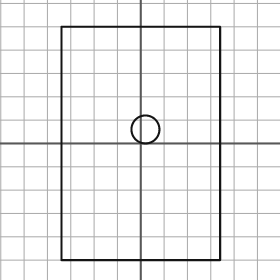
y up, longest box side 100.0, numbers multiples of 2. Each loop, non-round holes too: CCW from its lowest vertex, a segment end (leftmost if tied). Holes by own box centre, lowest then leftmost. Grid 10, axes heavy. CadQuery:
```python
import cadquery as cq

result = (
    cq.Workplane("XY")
    .moveTo(-34.0, -50.0)
    .lineTo(34.0, -50.0)
    .lineTo(34.0, 50.0)
    .lineTo(-34.0, 50.0)
    .close()
    .moveTo(2.0, 6.0)
    .circle(6.0)
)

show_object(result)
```